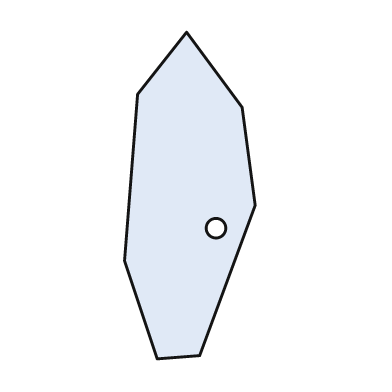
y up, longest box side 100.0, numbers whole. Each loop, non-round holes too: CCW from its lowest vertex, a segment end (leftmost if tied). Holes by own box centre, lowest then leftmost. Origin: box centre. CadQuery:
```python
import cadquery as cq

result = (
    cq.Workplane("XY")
    .moveTo(-10.0, -50.0)
    .lineTo(3.0, -49.0)
    .lineTo(20.0, -3.0)
    .lineTo(16.0, 27.0)
    .lineTo(-1.0, 50.0)
    .lineTo(-16.0, 31.0)
    .lineTo(-20.0, -20.0)
    .close()
    .moveTo(8.0, -10.0)
    .circle(3.0)
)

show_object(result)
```